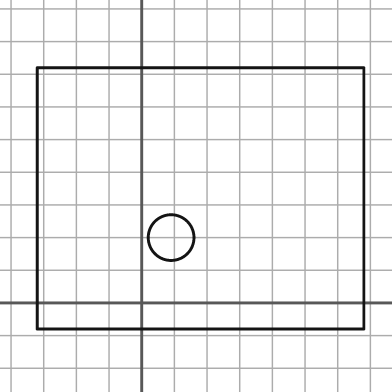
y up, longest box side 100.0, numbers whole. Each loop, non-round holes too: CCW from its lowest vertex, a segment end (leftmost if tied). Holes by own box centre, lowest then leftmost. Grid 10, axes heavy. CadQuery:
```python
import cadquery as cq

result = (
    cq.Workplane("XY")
    .moveTo(-32.0, -8.0)
    .lineTo(68.0, -8.0)
    .lineTo(68.0, 72.0)
    .lineTo(-32.0, 72.0)
    .close()
    .moveTo(9.0, 20.0)
    .circle(7.0)
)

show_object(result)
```